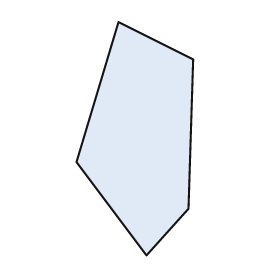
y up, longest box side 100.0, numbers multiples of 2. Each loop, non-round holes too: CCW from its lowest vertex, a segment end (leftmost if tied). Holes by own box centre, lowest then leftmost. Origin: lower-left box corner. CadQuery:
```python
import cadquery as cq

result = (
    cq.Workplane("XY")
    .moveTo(30.0, 0.0)
    .lineTo(48.0, 20.0)
    .lineTo(50.0, 84.0)
    .lineTo(18.0, 100.0)
    .lineTo(0.0, 40.0)
    .close()
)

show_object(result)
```